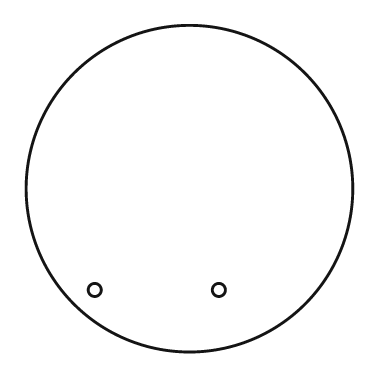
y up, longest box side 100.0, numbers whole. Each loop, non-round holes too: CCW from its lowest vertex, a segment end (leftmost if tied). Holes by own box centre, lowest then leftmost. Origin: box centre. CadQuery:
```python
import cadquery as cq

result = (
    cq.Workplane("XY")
    .moveTo(0.0, 0.0)
    .circle(50.0)
    .moveTo(-29.0, -31.0)
    .circle(2.0)
    .moveTo(9.0, -31.0)
    .circle(2.0)
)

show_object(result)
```